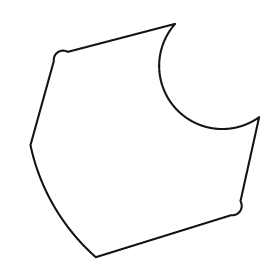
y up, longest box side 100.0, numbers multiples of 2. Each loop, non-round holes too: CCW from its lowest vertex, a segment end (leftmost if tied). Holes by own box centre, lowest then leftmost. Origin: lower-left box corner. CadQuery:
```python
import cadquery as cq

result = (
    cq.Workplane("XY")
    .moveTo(28.0, 0.0)
    .lineTo(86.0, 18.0)
    .threePointArc((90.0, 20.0), (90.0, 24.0))
    .lineTo(98.0, 60.0)
    .threePointArc((62.0, 64.0), (62.0, 100.0))
    .lineTo(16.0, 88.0)
    .threePointArc((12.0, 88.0), (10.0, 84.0))
    .lineTo(0.0, 48.0)
    .threePointArc((10.0, 22.0), (28.0, 0.0))
    .close()
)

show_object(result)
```